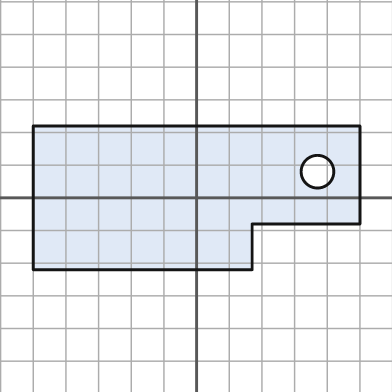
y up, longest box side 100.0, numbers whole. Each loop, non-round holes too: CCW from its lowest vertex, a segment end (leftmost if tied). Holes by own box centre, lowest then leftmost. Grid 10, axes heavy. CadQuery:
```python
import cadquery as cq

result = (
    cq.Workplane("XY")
    .moveTo(-50.0, -22.0)
    .lineTo(17.0, -22.0)
    .lineTo(17.0, -8.0)
    .lineTo(50.0, -8.0)
    .lineTo(50.0, 22.0)
    .lineTo(-50.0, 22.0)
    .close()
    .moveTo(37.0, 8.0)
    .circle(5.0)
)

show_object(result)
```